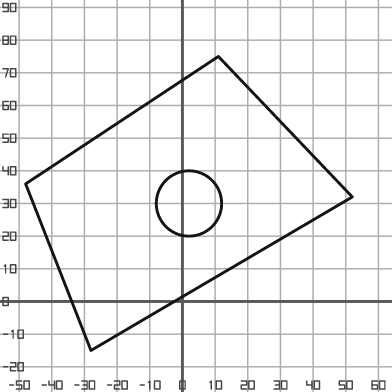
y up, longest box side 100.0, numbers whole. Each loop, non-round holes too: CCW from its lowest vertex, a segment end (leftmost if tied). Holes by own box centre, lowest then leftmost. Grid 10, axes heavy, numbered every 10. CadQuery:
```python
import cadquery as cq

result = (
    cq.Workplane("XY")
    .moveTo(-28.0, -15.0)
    .lineTo(52.0, 32.0)
    .lineTo(11.0, 75.0)
    .lineTo(-48.0, 36.0)
    .close()
    .moveTo(2.0, 30.0)
    .circle(10.0)
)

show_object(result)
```